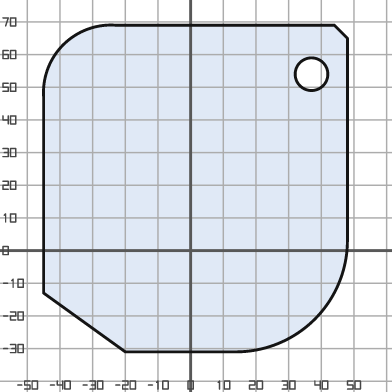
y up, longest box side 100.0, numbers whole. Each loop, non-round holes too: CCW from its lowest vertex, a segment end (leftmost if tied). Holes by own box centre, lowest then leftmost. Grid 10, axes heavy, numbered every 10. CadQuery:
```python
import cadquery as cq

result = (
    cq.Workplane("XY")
    .moveTo(-20.0, -31.0)
    .lineTo(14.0, -31.0)
    .threePointArc((38.0, -21.0), (48.0, 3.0))
    .lineTo(48.0, 65.0)
    .lineTo(44.0, 69.0)
    .lineTo(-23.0, 69.0)
    .threePointArc((-39.0, 63.0), (-45.0, 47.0))
    .lineTo(-45.0, -13.0)
    .close()
    .moveTo(37.0, 54.0)
    .circle(5.0)
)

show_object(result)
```